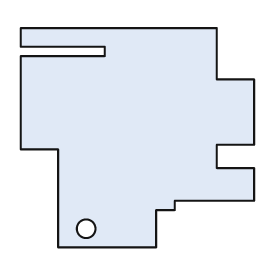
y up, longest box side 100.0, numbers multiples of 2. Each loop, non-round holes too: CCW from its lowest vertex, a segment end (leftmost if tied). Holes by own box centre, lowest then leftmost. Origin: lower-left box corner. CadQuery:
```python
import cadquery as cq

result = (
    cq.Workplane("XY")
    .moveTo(16.0, 0.0)
    .lineTo(58.0, 0.0)
    .lineTo(58.0, 16.0)
    .lineTo(66.0, 16.0)
    .lineTo(66.0, 20.0)
    .lineTo(100.0, 20.0)
    .lineTo(100.0, 34.0)
    .lineTo(84.0, 34.0)
    .lineTo(84.0, 44.0)
    .lineTo(100.0, 44.0)
    .lineTo(100.0, 72.0)
    .lineTo(84.0, 72.0)
    .lineTo(84.0, 94.0)
    .lineTo(0.0, 94.0)
    .lineTo(0.0, 86.0)
    .lineTo(36.0, 86.0)
    .lineTo(36.0, 82.0)
    .lineTo(0.0, 82.0)
    .lineTo(0.0, 42.0)
    .lineTo(16.0, 42.0)
    .close()
    .moveTo(28.0, 8.0)
    .circle(4.0)
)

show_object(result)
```